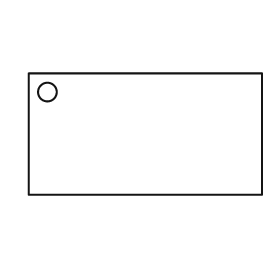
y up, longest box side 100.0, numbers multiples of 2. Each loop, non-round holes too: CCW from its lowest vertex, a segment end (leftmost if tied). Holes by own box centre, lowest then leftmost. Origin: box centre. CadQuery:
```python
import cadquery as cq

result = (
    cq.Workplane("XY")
    .moveTo(-50.0, -26.0)
    .lineTo(50.0, -26.0)
    .lineTo(50.0, 26.0)
    .lineTo(-50.0, 26.0)
    .close()
    .moveTo(-42.0, 18.0)
    .circle(4.0)
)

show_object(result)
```